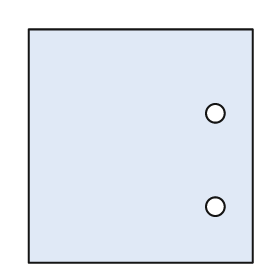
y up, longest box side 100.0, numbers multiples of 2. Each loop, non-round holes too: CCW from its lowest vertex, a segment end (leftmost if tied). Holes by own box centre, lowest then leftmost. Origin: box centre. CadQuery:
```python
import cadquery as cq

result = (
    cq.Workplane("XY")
    .moveTo(-48.0, -50.0)
    .lineTo(48.0, -50.0)
    .lineTo(48.0, 50.0)
    .lineTo(-48.0, 50.0)
    .close()
    .moveTo(32.0, -26.0)
    .circle(4.0)
    .moveTo(32.0, 14.0)
    .circle(4.0)
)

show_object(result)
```